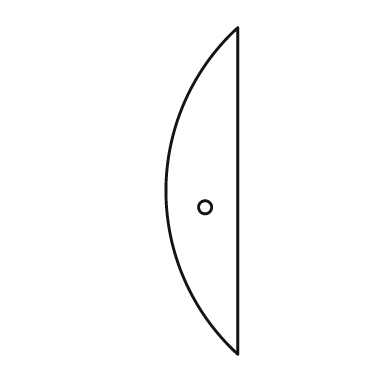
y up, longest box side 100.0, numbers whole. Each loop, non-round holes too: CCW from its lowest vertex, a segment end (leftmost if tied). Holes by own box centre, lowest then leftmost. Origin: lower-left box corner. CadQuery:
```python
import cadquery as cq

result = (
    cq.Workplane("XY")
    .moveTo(22.0, 0.0)
    .lineTo(22.0, 100.0)
    .threePointArc((0.0, 50.0), (22.0, 0.0))
    .close()
    .moveTo(12.0, 45.0)
    .circle(2.0)
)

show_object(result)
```